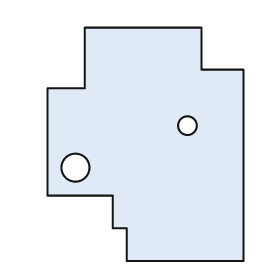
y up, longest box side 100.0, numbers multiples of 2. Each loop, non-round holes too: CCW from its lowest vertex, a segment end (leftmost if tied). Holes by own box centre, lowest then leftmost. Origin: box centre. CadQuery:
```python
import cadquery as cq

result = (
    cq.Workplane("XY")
    .moveTo(-8.0, -50.0)
    .lineTo(42.0, -50.0)
    .lineTo(42.0, 32.0)
    .lineTo(24.0, 32.0)
    .lineTo(24.0, 50.0)
    .lineTo(-26.0, 50.0)
    .lineTo(-26.0, 24.0)
    .lineTo(-42.0, 24.0)
    .lineTo(-42.0, -22.0)
    .lineTo(-14.0, -22.0)
    .lineTo(-14.0, -36.0)
    .lineTo(-8.0, -36.0)
    .close()
    .moveTo(-30.0, -10.0)
    .circle(6.0)
    .moveTo(18.0, 8.0)
    .circle(4.0)
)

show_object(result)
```